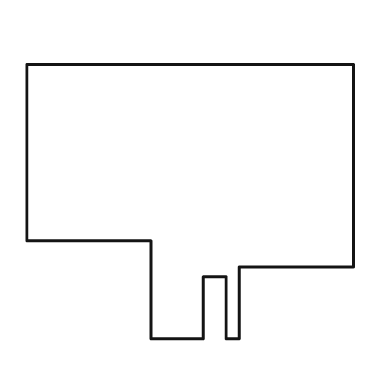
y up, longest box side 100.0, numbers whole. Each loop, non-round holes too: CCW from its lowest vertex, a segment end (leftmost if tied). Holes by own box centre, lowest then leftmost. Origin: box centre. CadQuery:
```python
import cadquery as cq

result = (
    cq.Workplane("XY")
    .moveTo(-12.0, -42.0)
    .lineTo(4.0, -42.0)
    .lineTo(4.0, -23.0)
    .lineTo(11.0, -23.0)
    .lineTo(11.0, -42.0)
    .lineTo(15.0, -42.0)
    .lineTo(15.0, -20.0)
    .lineTo(50.0, -20.0)
    .lineTo(50.0, 42.0)
    .lineTo(-50.0, 42.0)
    .lineTo(-50.0, -12.0)
    .lineTo(-12.0, -12.0)
    .close()
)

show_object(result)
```